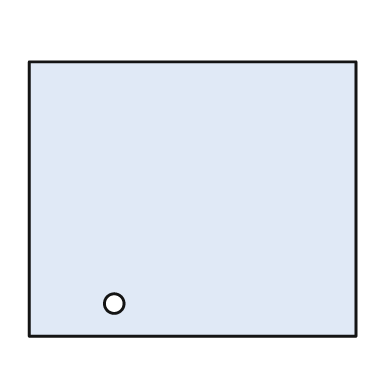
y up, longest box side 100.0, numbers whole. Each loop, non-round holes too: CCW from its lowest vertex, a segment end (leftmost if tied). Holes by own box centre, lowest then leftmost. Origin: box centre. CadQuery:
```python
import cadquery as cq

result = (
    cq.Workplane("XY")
    .moveTo(-50.0, -42.0)
    .lineTo(50.0, -42.0)
    .lineTo(50.0, 42.0)
    .lineTo(-50.0, 42.0)
    .close()
    .moveTo(-24.0, -32.0)
    .circle(3.0)
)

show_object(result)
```